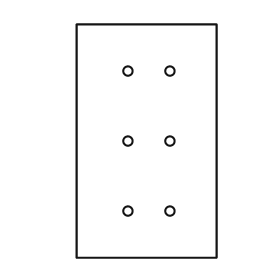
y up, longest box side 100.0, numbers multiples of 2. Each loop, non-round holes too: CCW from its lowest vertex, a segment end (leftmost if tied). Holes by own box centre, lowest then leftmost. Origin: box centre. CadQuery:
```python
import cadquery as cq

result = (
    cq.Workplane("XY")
    .moveTo(-30.0, -50.0)
    .lineTo(30.0, -50.0)
    .lineTo(30.0, 50.0)
    .lineTo(-30.0, 50.0)
    .close()
    .moveTo(-8.0, -30.0)
    .circle(2.0)
    .moveTo(10.0, -30.0)
    .circle(2.0)
    .moveTo(-8.0, 0.0)
    .circle(2.0)
    .moveTo(10.0, 0.0)
    .circle(2.0)
    .moveTo(-8.0, 30.0)
    .circle(2.0)
    .moveTo(10.0, 30.0)
    .circle(2.0)
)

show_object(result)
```